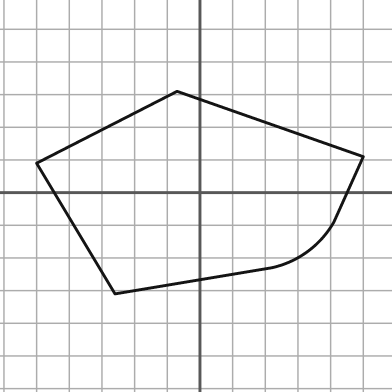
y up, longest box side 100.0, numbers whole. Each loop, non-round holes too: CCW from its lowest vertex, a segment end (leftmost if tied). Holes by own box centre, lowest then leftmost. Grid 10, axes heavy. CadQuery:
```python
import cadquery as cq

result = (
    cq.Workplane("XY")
    .moveTo(-26.0, -31.0)
    .lineTo(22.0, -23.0)
    .threePointArc((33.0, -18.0), (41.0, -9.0))
    .lineTo(50.0, 11.0)
    .lineTo(-7.0, 31.0)
    .lineTo(-50.0, 9.0)
    .close()
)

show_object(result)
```